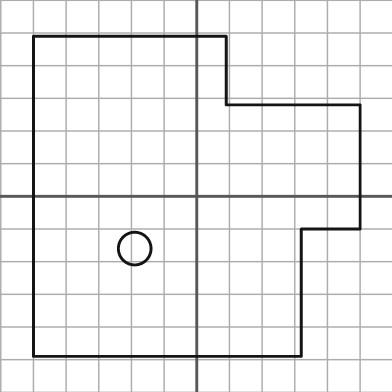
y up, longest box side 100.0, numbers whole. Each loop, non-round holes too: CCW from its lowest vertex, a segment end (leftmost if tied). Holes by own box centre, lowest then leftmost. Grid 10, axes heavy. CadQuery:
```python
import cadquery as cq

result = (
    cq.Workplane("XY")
    .moveTo(-50.0, -49.0)
    .lineTo(32.0, -49.0)
    .lineTo(32.0, -10.0)
    .lineTo(50.0, -10.0)
    .lineTo(50.0, 28.0)
    .lineTo(9.0, 28.0)
    .lineTo(9.0, 49.0)
    .lineTo(-50.0, 49.0)
    .close()
    .moveTo(-19.0, -16.0)
    .circle(5.0)
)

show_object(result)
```